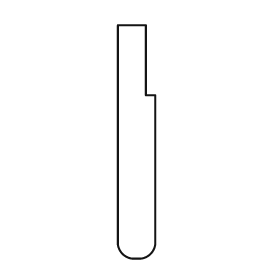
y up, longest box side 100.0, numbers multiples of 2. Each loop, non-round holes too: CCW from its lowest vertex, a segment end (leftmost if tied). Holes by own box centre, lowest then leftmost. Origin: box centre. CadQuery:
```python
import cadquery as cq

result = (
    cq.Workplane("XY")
    .moveTo(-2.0, -50.0)
    .lineTo(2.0, -50.0)
    .threePointArc((6.0, -48.0), (8.0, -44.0))
    .lineTo(8.0, 20.0)
    .lineTo(4.0, 20.0)
    .lineTo(4.0, 50.0)
    .lineTo(-8.0, 50.0)
    .lineTo(-8.0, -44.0)
    .threePointArc((-6.0, -48.0), (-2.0, -50.0))
    .close()
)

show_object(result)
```